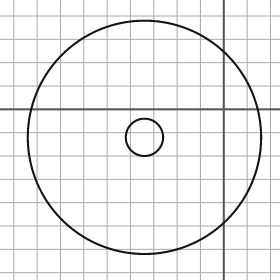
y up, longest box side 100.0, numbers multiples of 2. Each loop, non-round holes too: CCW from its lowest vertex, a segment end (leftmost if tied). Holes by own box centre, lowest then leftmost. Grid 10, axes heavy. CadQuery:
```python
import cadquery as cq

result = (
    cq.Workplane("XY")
    .moveTo(-34.0, -12.0)
    .circle(50.0)
    .moveTo(-34.0, -12.0)
    .circle(8.0)
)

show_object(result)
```